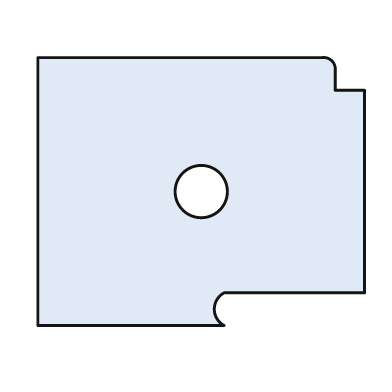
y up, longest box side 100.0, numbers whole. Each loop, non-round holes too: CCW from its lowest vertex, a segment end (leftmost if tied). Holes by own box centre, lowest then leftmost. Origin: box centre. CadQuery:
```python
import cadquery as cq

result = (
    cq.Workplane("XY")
    .moveTo(-50.0, -41.0)
    .lineTo(7.0, -41.0)
    .threePointArc((4.0, -36.0), (7.0, -31.0))
    .lineTo(50.0, -31.0)
    .lineTo(50.0, 31.0)
    .lineTo(41.0, 31.0)
    .lineTo(41.0, 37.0)
    .threePointArc((40.0, 40.0), (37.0, 41.0))
    .lineTo(-50.0, 41.0)
    .close()
    .moveTo(0.0, 0.0)
    .circle(8.0)
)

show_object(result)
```